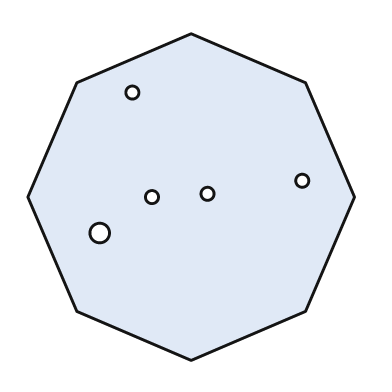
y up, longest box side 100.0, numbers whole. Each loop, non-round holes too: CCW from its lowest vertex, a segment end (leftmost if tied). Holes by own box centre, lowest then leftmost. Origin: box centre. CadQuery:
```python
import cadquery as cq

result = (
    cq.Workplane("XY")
    .moveTo(0.0, -50.0)
    .lineTo(35.0, -35.0)
    .lineTo(50.0, 0.0)
    .lineTo(35.0, 35.0)
    .lineTo(0.0, 50.0)
    .lineTo(-35.0, 35.0)
    .lineTo(-50.0, 0.0)
    .lineTo(-35.0, -35.0)
    .close()
    .moveTo(-28.0, -11.0)
    .circle(3.0)
    .moveTo(-12.0, 0.0)
    .circle(2.0)
    .moveTo(5.0, 1.0)
    .circle(2.0)
    .moveTo(34.0, 5.0)
    .circle(2.0)
    .moveTo(-18.0, 32.0)
    .circle(2.0)
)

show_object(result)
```